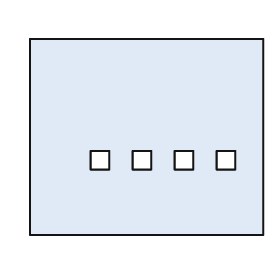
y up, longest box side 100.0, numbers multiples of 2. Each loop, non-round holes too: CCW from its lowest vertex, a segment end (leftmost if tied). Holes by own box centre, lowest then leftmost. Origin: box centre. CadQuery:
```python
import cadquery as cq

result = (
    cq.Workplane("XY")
    .moveTo(-50.0, -42.0)
    .lineTo(50.0, -42.0)
    .lineTo(50.0, 42.0)
    .lineTo(-50.0, 42.0)
    .close()
    .moveTo(-24.0, -14.0)
    .lineTo(-16.0, -14.0)
    .lineTo(-16.0, -6.0)
    .lineTo(-24.0, -6.0)
    .close()
    .moveTo(-6.0, -14.0)
    .lineTo(2.0, -14.0)
    .lineTo(2.0, -6.0)
    .lineTo(-6.0, -6.0)
    .close()
    .moveTo(12.0, -14.0)
    .lineTo(20.0, -14.0)
    .lineTo(20.0, -6.0)
    .lineTo(12.0, -6.0)
    .close()
    .moveTo(30.0, -14.0)
    .lineTo(38.0, -14.0)
    .lineTo(38.0, -6.0)
    .lineTo(30.0, -6.0)
    .close()
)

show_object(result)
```